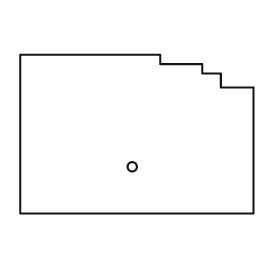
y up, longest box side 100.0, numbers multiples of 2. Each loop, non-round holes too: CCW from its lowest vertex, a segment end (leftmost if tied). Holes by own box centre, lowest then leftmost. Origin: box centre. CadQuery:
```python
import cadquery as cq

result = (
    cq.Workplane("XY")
    .moveTo(-50.0, -34.0)
    .lineTo(50.0, -34.0)
    .lineTo(50.0, 20.0)
    .lineTo(36.0, 20.0)
    .lineTo(36.0, 26.0)
    .lineTo(28.0, 26.0)
    .lineTo(28.0, 30.0)
    .lineTo(10.0, 30.0)
    .lineTo(10.0, 34.0)
    .lineTo(-50.0, 34.0)
    .close()
    .moveTo(-2.0, -14.0)
    .circle(2.0)
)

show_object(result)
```